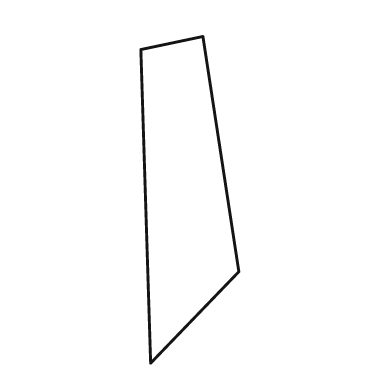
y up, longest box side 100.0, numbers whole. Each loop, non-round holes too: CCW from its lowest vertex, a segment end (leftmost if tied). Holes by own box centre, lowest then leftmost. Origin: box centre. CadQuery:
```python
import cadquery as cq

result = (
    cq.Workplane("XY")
    .moveTo(-12.0, -50.0)
    .lineTo(15.0, -22.0)
    .lineTo(4.0, 50.0)
    .lineTo(-15.0, 46.0)
    .close()
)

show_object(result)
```